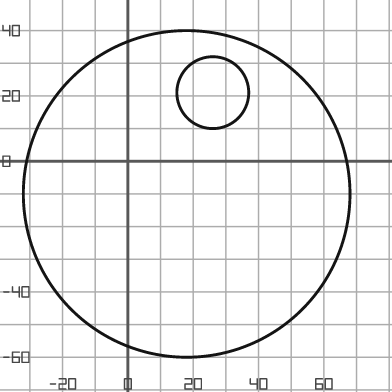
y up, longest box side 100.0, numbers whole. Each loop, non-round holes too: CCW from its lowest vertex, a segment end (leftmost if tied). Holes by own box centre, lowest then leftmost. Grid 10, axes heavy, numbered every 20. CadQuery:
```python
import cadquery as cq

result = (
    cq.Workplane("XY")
    .moveTo(18.0, -10.0)
    .circle(50.0)
    .moveTo(26.0, 21.0)
    .circle(11.0)
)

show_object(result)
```